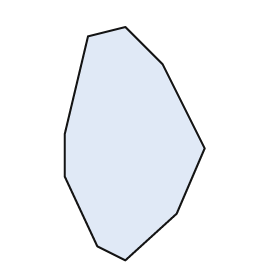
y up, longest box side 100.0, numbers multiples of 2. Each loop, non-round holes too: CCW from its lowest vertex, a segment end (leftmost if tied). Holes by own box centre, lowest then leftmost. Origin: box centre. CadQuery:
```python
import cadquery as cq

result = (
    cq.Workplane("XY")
    .moveTo(-4.0, -50.0)
    .lineTo(18.0, -30.0)
    .lineTo(30.0, -2.0)
    .lineTo(12.0, 34.0)
    .lineTo(-4.0, 50.0)
    .lineTo(-20.0, 46.0)
    .lineTo(-30.0, 4.0)
    .lineTo(-30.0, -14.0)
    .lineTo(-16.0, -44.0)
    .close()
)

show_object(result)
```